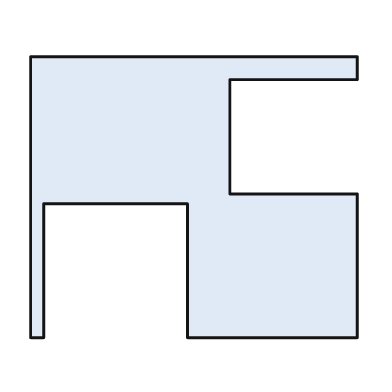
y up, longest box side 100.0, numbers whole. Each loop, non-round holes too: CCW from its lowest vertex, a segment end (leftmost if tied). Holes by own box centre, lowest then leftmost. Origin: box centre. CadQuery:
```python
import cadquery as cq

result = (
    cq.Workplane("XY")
    .moveTo(-50.0, -43.0)
    .lineTo(-46.0, -43.0)
    .lineTo(-46.0, -2.0)
    .lineTo(-2.0, -2.0)
    .lineTo(-2.0, -43.0)
    .lineTo(50.0, -43.0)
    .lineTo(50.0, 1.0)
    .lineTo(11.0, 1.0)
    .lineTo(11.0, 36.0)
    .lineTo(50.0, 36.0)
    .lineTo(50.0, 43.0)
    .lineTo(-50.0, 43.0)
    .close()
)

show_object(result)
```